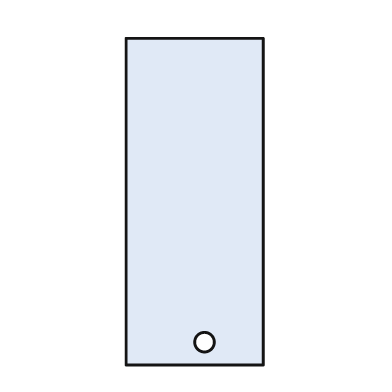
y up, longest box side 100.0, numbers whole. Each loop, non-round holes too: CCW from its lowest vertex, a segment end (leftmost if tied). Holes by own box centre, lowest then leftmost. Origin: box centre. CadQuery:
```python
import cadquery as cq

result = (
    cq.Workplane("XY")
    .moveTo(-21.0, -50.0)
    .lineTo(21.0, -50.0)
    .lineTo(21.0, 50.0)
    .lineTo(-21.0, 50.0)
    .close()
    .moveTo(3.0, -43.0)
    .circle(3.0)
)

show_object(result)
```